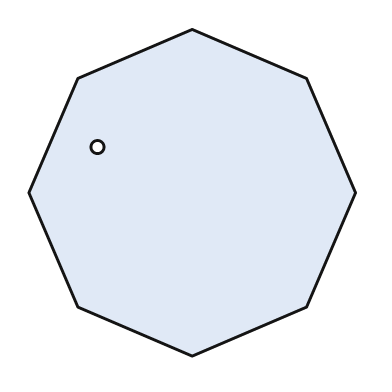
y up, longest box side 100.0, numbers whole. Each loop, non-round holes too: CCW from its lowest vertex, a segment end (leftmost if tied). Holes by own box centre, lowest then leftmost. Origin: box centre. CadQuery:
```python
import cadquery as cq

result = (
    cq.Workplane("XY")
    .moveTo(0.0, -50.0)
    .lineTo(35.0, -35.0)
    .lineTo(50.0, 0.0)
    .lineTo(35.0, 35.0)
    .lineTo(0.0, 50.0)
    .lineTo(-35.0, 35.0)
    .lineTo(-50.0, 0.0)
    .lineTo(-35.0, -35.0)
    .close()
    .moveTo(-29.0, 14.0)
    .circle(2.0)
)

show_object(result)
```